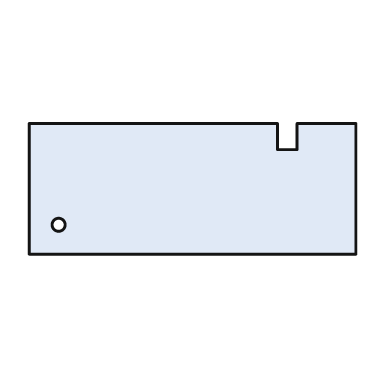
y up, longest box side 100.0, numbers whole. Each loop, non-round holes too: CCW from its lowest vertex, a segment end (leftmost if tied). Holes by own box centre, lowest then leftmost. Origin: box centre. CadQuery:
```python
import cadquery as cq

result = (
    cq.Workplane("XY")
    .moveTo(-50.0, -20.0)
    .lineTo(50.0, -20.0)
    .lineTo(50.0, 20.0)
    .lineTo(32.0, 20.0)
    .lineTo(32.0, 12.0)
    .lineTo(26.0, 12.0)
    .lineTo(26.0, 20.0)
    .lineTo(-50.0, 20.0)
    .close()
    .moveTo(-41.0, -11.0)
    .circle(2.0)
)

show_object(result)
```